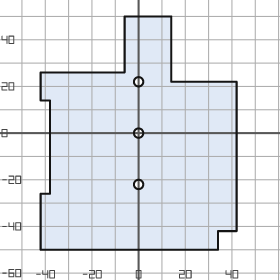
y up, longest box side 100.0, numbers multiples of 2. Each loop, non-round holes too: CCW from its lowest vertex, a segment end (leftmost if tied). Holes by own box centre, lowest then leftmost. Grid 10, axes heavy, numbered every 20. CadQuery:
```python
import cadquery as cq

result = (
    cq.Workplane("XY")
    .moveTo(-42.0, -50.0)
    .lineTo(34.0, -50.0)
    .lineTo(34.0, -42.0)
    .lineTo(42.0, -42.0)
    .lineTo(42.0, 22.0)
    .lineTo(14.0, 22.0)
    .lineTo(14.0, 50.0)
    .lineTo(-6.0, 50.0)
    .lineTo(-6.0, 26.0)
    .lineTo(-42.0, 26.0)
    .lineTo(-42.0, 14.0)
    .lineTo(-38.0, 14.0)
    .lineTo(-38.0, -26.0)
    .lineTo(-42.0, -26.0)
    .close()
    .moveTo(0.0, -22.0)
    .circle(2.0)
    .moveTo(0.0, 0.0)
    .circle(2.0)
    .moveTo(0.0, 22.0)
    .circle(2.0)
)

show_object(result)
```